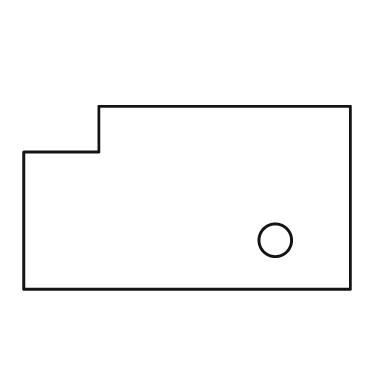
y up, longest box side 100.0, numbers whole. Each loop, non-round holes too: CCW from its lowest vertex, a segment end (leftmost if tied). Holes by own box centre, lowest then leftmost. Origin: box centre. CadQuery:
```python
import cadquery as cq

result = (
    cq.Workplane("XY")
    .moveTo(-50.0, -28.0)
    .lineTo(50.0, -28.0)
    .lineTo(50.0, 28.0)
    .lineTo(-27.0, 28.0)
    .lineTo(-27.0, 14.0)
    .lineTo(-50.0, 14.0)
    .close()
    .moveTo(27.0, -13.0)
    .circle(5.0)
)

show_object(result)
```